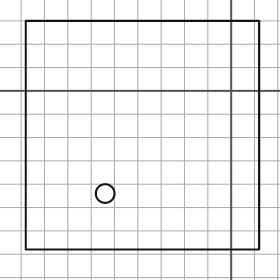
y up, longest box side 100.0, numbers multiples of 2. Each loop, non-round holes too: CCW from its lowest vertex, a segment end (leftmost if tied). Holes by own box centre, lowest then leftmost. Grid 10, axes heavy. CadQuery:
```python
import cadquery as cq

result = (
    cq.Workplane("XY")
    .moveTo(-88.0, -68.0)
    .lineTo(12.0, -68.0)
    .lineTo(12.0, 30.0)
    .lineTo(-88.0, 30.0)
    .close()
    .moveTo(-54.0, -44.0)
    .circle(4.0)
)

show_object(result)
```